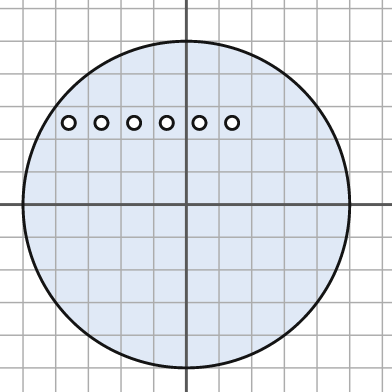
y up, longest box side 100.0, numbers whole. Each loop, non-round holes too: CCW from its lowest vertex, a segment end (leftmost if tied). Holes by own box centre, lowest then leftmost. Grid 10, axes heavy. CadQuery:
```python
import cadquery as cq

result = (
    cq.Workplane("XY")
    .moveTo(0.0, 0.0)
    .circle(50.0)
    .moveTo(-36.0, 25.0)
    .circle(2.0)
    .moveTo(-26.0, 25.0)
    .circle(2.0)
    .moveTo(-16.0, 25.0)
    .circle(2.0)
    .moveTo(-6.0, 25.0)
    .circle(2.0)
    .moveTo(4.0, 25.0)
    .circle(2.0)
    .moveTo(14.0, 25.0)
    .circle(2.0)
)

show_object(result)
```